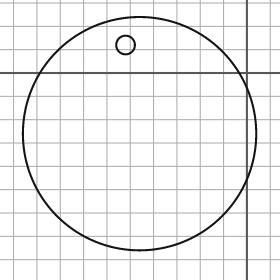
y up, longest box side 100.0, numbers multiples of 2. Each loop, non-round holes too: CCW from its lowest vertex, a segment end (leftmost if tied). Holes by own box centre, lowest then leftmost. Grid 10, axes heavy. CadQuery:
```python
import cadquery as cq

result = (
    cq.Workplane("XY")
    .moveTo(-46.0, -26.0)
    .circle(50.0)
    .moveTo(-52.0, 12.0)
    .circle(4.0)
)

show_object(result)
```